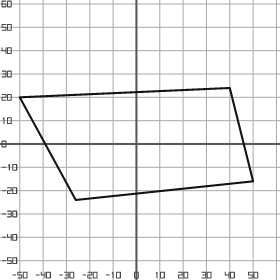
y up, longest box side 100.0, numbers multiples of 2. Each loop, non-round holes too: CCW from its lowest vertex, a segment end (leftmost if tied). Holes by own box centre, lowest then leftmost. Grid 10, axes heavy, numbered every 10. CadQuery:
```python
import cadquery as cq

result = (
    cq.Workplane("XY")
    .moveTo(-26.0, -24.0)
    .lineTo(50.0, -16.0)
    .lineTo(40.0, 24.0)
    .lineTo(-50.0, 20.0)
    .close()
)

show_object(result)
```